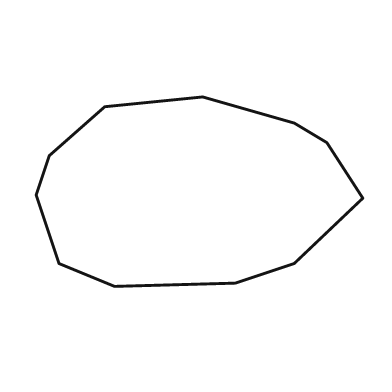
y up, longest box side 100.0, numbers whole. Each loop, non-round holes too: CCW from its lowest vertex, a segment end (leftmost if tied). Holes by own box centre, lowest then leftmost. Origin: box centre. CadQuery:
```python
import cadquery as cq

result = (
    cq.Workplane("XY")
    .moveTo(-26.0, -29.0)
    .lineTo(11.0, -28.0)
    .lineTo(29.0, -22.0)
    .lineTo(50.0, -2.0)
    .lineTo(39.0, 15.0)
    .lineTo(29.0, 21.0)
    .lineTo(1.0, 29.0)
    .lineTo(-29.0, 26.0)
    .lineTo(-46.0, 11.0)
    .lineTo(-50.0, -1.0)
    .lineTo(-43.0, -22.0)
    .close()
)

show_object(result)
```